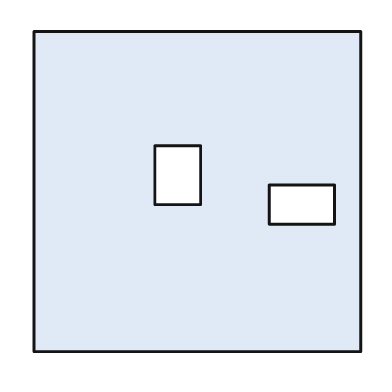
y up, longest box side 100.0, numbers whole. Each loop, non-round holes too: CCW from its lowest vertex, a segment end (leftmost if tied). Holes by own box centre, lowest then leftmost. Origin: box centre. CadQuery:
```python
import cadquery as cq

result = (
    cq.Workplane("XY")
    .moveTo(-50.0, -49.0)
    .lineTo(50.0, -49.0)
    .lineTo(50.0, 49.0)
    .lineTo(-50.0, 49.0)
    .close()
    .moveTo(22.0, -10.0)
    .lineTo(42.0, -10.0)
    .lineTo(42.0, 2.0)
    .lineTo(22.0, 2.0)
    .close()
    .moveTo(-13.0, -4.0)
    .lineTo(1.0, -4.0)
    .lineTo(1.0, 14.0)
    .lineTo(-13.0, 14.0)
    .close()
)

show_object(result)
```